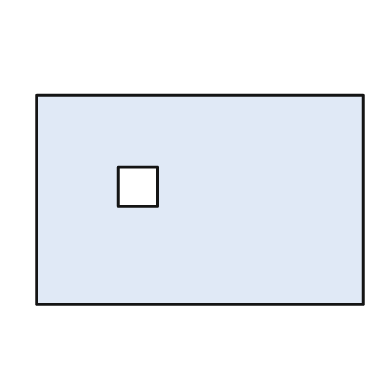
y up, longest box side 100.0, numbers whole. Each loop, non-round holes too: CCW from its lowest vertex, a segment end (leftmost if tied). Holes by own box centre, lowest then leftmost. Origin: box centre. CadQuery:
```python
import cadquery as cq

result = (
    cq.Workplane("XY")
    .moveTo(-50.0, -32.0)
    .lineTo(50.0, -32.0)
    .lineTo(50.0, 32.0)
    .lineTo(-50.0, 32.0)
    .close()
    .moveTo(-25.0, -2.0)
    .lineTo(-13.0, -2.0)
    .lineTo(-13.0, 10.0)
    .lineTo(-25.0, 10.0)
    .close()
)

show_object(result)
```